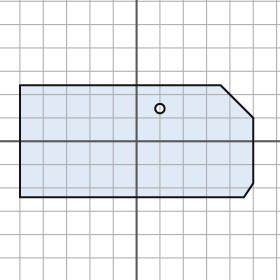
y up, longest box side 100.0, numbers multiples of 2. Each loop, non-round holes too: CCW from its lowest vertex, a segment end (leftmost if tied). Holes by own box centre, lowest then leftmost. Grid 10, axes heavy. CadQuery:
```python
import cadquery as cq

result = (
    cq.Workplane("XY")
    .moveTo(-50.0, -24.0)
    .lineTo(46.0, -24.0)
    .lineTo(50.0, -18.0)
    .lineTo(50.0, 10.0)
    .lineTo(36.0, 24.0)
    .lineTo(-50.0, 24.0)
    .close()
    .moveTo(10.0, 14.0)
    .circle(2.0)
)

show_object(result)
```